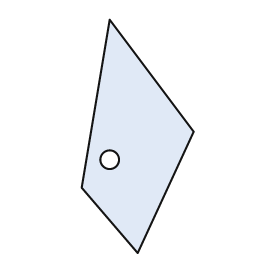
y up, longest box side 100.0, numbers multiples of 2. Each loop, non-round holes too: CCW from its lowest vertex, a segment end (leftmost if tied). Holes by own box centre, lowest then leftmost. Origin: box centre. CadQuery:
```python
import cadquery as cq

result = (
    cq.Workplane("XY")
    .moveTo(0.0, -50.0)
    .lineTo(24.0, 2.0)
    .lineTo(-12.0, 50.0)
    .lineTo(-24.0, -22.0)
    .close()
    .moveTo(-12.0, -10.0)
    .circle(4.0)
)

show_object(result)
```